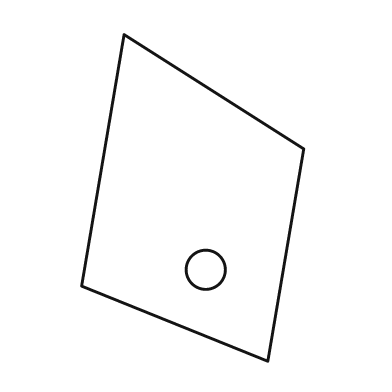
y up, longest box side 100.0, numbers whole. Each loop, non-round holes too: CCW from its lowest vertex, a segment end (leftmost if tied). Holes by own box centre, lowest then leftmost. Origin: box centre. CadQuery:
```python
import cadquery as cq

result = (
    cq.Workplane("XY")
    .moveTo(23.0, -50.0)
    .lineTo(34.0, 15.0)
    .lineTo(-21.0, 50.0)
    .lineTo(-34.0, -27.0)
    .close()
    .moveTo(4.0, -22.0)
    .circle(6.0)
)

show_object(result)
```